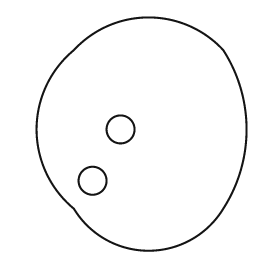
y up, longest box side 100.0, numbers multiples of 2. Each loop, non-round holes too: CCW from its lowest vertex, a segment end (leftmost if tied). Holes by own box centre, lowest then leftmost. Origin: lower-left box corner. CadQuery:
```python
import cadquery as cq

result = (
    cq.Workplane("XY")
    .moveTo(16.0, 18.0)
    .threePointArc((48.0, 0.0), (80.0, 18.0))
    .threePointArc((90.0, 52.0), (80.0, 86.0))
    .threePointArc((48.0, 100.0), (16.0, 86.0))
    .threePointArc((0.0, 52.0), (16.0, 18.0))
    .close()
    .moveTo(24.0, 30.0)
    .circle(6.0)
    .moveTo(36.0, 52.0)
    .circle(6.0)
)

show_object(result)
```